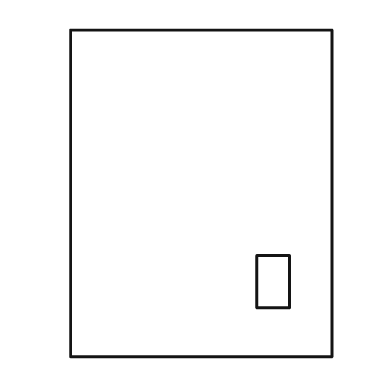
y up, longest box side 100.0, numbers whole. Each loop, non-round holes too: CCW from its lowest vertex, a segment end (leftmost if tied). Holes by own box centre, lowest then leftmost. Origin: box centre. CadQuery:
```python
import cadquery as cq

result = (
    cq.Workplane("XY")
    .moveTo(-40.0, -50.0)
    .lineTo(40.0, -50.0)
    .lineTo(40.0, 50.0)
    .lineTo(-40.0, 50.0)
    .close()
    .moveTo(17.0, -35.0)
    .lineTo(27.0, -35.0)
    .lineTo(27.0, -19.0)
    .lineTo(17.0, -19.0)
    .close()
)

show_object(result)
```